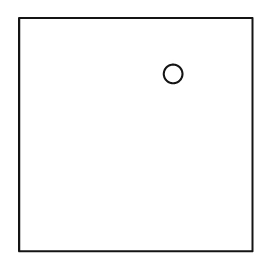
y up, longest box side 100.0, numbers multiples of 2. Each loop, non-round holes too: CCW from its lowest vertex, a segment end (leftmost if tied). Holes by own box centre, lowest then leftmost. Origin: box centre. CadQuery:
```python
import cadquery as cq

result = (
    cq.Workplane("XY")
    .moveTo(-50.0, -50.0)
    .lineTo(50.0, -50.0)
    .lineTo(50.0, 50.0)
    .lineTo(-50.0, 50.0)
    .close()
    .moveTo(16.0, 26.0)
    .circle(4.0)
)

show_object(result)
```